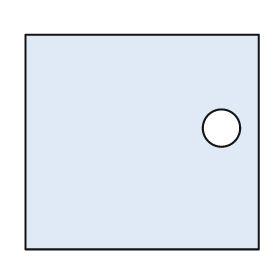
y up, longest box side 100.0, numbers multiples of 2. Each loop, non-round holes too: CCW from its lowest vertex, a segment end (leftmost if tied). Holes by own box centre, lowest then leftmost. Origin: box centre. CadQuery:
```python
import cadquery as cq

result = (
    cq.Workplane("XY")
    .moveTo(-50.0, -46.0)
    .lineTo(50.0, -46.0)
    .lineTo(50.0, 46.0)
    .lineTo(-50.0, 46.0)
    .close()
    .moveTo(34.0, 6.0)
    .circle(8.0)
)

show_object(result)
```